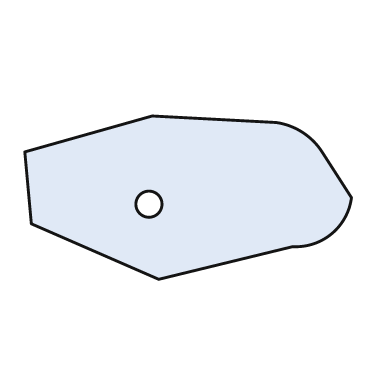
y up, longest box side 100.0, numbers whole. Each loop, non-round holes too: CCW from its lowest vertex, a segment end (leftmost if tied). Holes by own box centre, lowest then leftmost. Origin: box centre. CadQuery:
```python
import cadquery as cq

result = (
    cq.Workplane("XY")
    .moveTo(-9.0, -25.0)
    .lineTo(32.0, -15.0)
    .threePointArc((44.0, -11.0), (50.0, 0.0))
    .lineTo(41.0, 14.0)
    .threePointArc((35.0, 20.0), (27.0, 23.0))
    .lineTo(-11.0, 25.0)
    .lineTo(-50.0, 14.0)
    .lineTo(-48.0, -8.0)
    .close()
    .moveTo(-12.0, -2.0)
    .circle(4.0)
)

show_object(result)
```